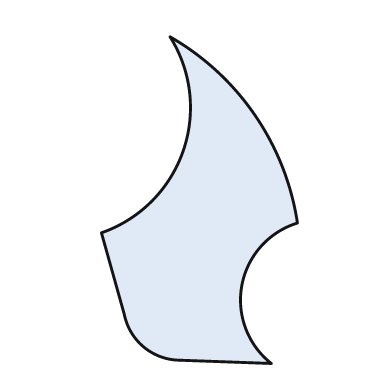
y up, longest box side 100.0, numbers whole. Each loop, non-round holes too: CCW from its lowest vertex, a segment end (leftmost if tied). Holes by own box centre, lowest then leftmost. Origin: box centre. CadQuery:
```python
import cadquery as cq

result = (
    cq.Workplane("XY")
    .moveTo(22.0, -50.0)
    .threePointArc((13.0, -26.0), (30.0, -7.0))
    .threePointArc((17.0, 26.0), (-9.0, 50.0))
    .threePointArc((-5.0, 15.0), (-30.0, -10.0))
    .lineTo(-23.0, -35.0)
    .threePointArc((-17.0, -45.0), (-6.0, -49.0))
    .close()
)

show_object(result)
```